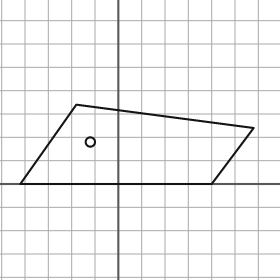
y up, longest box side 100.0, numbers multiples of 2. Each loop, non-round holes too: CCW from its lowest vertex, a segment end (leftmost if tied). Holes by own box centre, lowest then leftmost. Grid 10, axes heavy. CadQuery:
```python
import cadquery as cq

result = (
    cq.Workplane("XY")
    .moveTo(-42.0, 0.0)
    .lineTo(40.0, 0.0)
    .lineTo(58.0, 24.0)
    .lineTo(-18.0, 34.0)
    .close()
    .moveTo(-12.0, 18.0)
    .circle(2.0)
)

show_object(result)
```